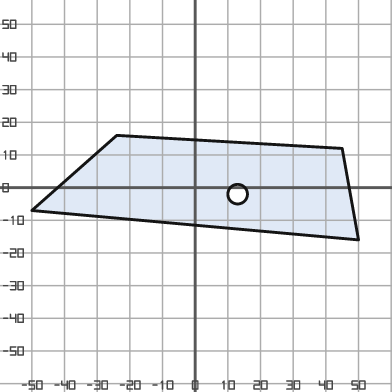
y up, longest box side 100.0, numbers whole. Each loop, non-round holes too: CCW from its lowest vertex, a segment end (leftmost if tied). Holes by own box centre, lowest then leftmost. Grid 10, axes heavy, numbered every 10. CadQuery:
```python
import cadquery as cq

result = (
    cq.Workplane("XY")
    .moveTo(50.0, -16.0)
    .lineTo(45.0, 12.0)
    .lineTo(-24.0, 16.0)
    .lineTo(-50.0, -7.0)
    .close()
    .moveTo(13.0, -2.0)
    .circle(3.0)
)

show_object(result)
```